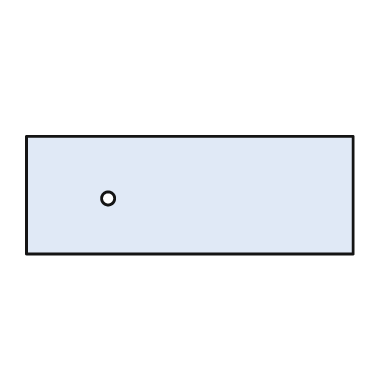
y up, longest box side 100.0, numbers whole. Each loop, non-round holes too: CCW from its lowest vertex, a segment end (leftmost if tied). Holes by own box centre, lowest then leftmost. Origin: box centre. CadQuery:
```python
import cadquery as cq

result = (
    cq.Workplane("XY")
    .moveTo(-50.0, -18.0)
    .lineTo(50.0, -18.0)
    .lineTo(50.0, 18.0)
    .lineTo(-50.0, 18.0)
    .close()
    .moveTo(-25.0, -1.0)
    .circle(2.0)
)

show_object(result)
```